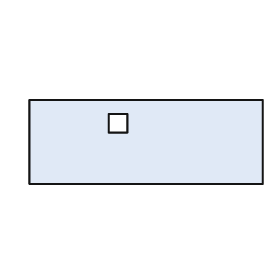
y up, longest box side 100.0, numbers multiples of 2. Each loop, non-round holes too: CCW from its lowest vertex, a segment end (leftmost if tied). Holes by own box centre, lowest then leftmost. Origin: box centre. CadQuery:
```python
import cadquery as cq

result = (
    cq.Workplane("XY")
    .moveTo(-50.0, -18.0)
    .lineTo(50.0, -18.0)
    .lineTo(50.0, 18.0)
    .lineTo(-50.0, 18.0)
    .close()
    .moveTo(-16.0, 4.0)
    .lineTo(-8.0, 4.0)
    .lineTo(-8.0, 12.0)
    .lineTo(-16.0, 12.0)
    .close()
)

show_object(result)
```